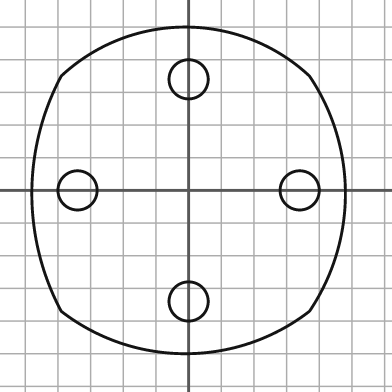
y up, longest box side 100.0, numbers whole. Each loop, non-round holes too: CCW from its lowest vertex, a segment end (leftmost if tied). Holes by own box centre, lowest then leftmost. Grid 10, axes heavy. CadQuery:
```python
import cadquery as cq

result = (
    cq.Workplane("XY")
    .moveTo(-39.0, -37.0)
    .threePointArc((-1.0, -50.0), (37.0, -37.0))
    .threePointArc((48.0, -1.0), (37.0, 35.0))
    .threePointArc((-1.0, 50.0), (-39.0, 35.0))
    .threePointArc((-48.0, -1.0), (-39.0, -37.0))
    .close()
    .moveTo(0.0, -34.0)
    .circle(6.0)
    .moveTo(-34.0, 0.0)
    .circle(6.0)
    .moveTo(34.0, 0.0)
    .circle(6.0)
    .moveTo(0.0, 34.0)
    .circle(6.0)
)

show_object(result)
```